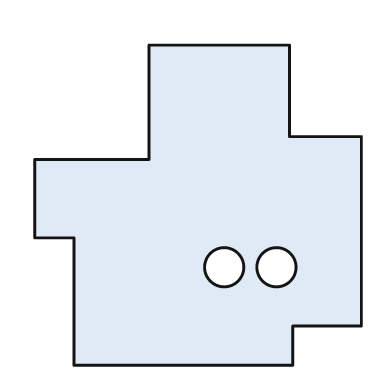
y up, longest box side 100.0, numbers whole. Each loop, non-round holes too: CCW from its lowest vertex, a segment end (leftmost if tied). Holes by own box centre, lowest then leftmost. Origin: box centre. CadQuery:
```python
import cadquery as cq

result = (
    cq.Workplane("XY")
    .moveTo(-38.0, -49.0)
    .lineTo(29.0, -49.0)
    .lineTo(29.0, -37.0)
    .lineTo(50.0, -37.0)
    .lineTo(50.0, 21.0)
    .lineTo(28.0, 21.0)
    .lineTo(28.0, 49.0)
    .lineTo(-15.0, 49.0)
    .lineTo(-15.0, 14.0)
    .lineTo(-50.0, 14.0)
    .lineTo(-50.0, -10.0)
    .lineTo(-38.0, -10.0)
    .close()
    .moveTo(8.0, -19.0)
    .circle(6.0)
    .moveTo(24.0, -19.0)
    .circle(6.0)
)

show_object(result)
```